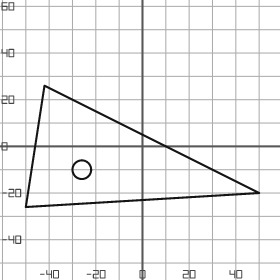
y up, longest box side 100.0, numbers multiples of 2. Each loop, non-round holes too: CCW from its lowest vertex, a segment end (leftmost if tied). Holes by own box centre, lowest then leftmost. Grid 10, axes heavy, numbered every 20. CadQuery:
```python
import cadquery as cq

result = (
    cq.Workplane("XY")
    .moveTo(-50.0, -26.0)
    .lineTo(50.0, -20.0)
    .lineTo(-42.0, 26.0)
    .close()
    .moveTo(-26.0, -10.0)
    .circle(4.0)
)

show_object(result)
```